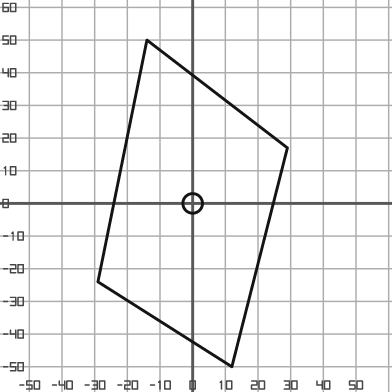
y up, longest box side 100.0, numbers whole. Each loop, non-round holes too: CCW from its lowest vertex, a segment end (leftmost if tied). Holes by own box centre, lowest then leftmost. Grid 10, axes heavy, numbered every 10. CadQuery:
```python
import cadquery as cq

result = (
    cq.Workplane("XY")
    .moveTo(12.0, -50.0)
    .lineTo(29.0, 17.0)
    .lineTo(-14.0, 50.0)
    .lineTo(-29.0, -24.0)
    .close()
    .moveTo(0.0, 0.0)
    .circle(3.0)
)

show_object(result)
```